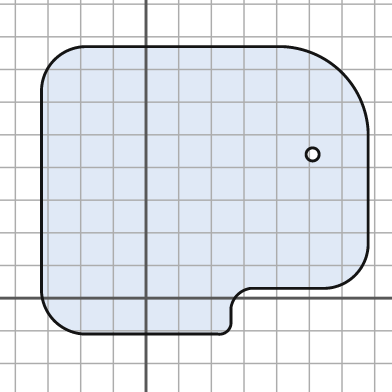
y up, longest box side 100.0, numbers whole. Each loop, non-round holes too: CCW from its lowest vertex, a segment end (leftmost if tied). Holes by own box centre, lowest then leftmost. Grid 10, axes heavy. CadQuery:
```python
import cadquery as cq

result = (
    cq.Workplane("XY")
    .moveTo(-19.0, -11.0)
    .lineTo(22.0, -11.0)
    .threePointArc((25.0, -10.0), (26.0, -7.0))
    .lineTo(26.0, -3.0)
    .threePointArc((28.0, 1.0), (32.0, 3.0))
    .lineTo(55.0, 3.0)
    .threePointArc((64.0, 7.0), (68.0, 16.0))
    .lineTo(68.0, 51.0)
    .threePointArc((60.0, 69.0), (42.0, 77.0))
    .lineTo(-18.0, 77.0)
    .threePointArc((-28.0, 73.0), (-32.0, 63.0))
    .lineTo(-32.0, 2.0)
    .threePointArc((-28.0, -7.0), (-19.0, -11.0))
    .close()
    .moveTo(51.0, 44.0)
    .circle(2.0)
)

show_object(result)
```